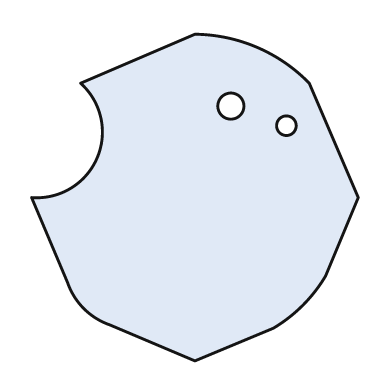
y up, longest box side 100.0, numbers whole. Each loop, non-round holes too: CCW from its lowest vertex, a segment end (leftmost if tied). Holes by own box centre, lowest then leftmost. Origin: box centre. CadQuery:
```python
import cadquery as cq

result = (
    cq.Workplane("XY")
    .moveTo(0.0, -50.0)
    .lineTo(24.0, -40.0)
    .threePointArc((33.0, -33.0), (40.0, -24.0))
    .lineTo(50.0, 0.0)
    .lineTo(35.0, 35.0)
    .threePointArc((19.0, 46.0), (0.0, 50.0))
    .lineTo(-35.0, 35.0)
    .threePointArc((-30.0, 12.0), (-50.0, 0.0))
    .lineTo(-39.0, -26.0)
    .threePointArc((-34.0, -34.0), (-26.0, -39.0))
    .close()
    .moveTo(28.0, 22.0)
    .circle(3.0)
    .moveTo(11.0, 28.0)
    .circle(4.0)
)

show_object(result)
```